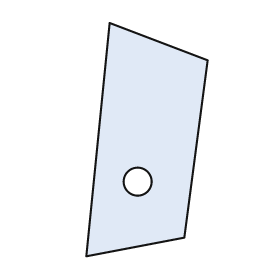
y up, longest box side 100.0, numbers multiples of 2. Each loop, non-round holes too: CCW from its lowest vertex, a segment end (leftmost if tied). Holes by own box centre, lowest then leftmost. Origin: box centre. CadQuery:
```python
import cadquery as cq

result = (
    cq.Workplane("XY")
    .moveTo(-26.0, -50.0)
    .lineTo(16.0, -42.0)
    .lineTo(26.0, 34.0)
    .lineTo(-16.0, 50.0)
    .close()
    .moveTo(-4.0, -18.0)
    .circle(6.0)
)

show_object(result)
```